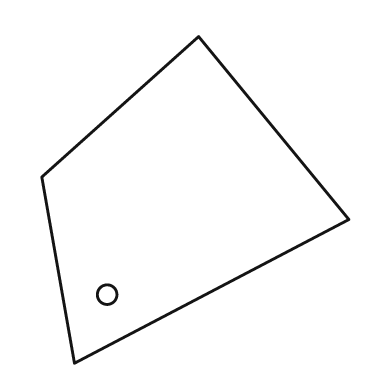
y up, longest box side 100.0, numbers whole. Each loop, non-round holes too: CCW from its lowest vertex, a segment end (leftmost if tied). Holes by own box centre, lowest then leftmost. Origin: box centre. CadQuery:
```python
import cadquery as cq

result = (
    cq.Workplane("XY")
    .moveTo(-37.0, -50.0)
    .lineTo(47.0, -6.0)
    .lineTo(1.0, 50.0)
    .lineTo(-47.0, 7.0)
    .close()
    .moveTo(-27.0, -29.0)
    .circle(3.0)
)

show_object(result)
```